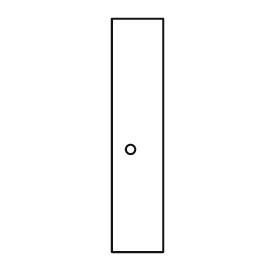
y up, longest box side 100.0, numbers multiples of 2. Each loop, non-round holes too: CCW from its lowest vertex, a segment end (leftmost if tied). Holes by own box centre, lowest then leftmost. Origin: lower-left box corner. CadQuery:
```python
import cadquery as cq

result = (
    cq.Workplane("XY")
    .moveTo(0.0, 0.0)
    .lineTo(22.0, 0.0)
    .lineTo(22.0, 100.0)
    .lineTo(0.0, 100.0)
    .close()
    .moveTo(8.0, 44.0)
    .circle(2.0)
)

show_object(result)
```